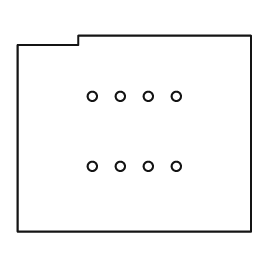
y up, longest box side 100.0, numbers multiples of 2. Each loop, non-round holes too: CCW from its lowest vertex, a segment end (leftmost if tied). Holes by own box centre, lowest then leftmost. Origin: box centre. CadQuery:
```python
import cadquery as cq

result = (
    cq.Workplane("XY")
    .moveTo(-50.0, -42.0)
    .lineTo(50.0, -42.0)
    .lineTo(50.0, 42.0)
    .lineTo(-24.0, 42.0)
    .lineTo(-24.0, 38.0)
    .lineTo(-50.0, 38.0)
    .close()
    .moveTo(-18.0, -14.0)
    .circle(2.0)
    .moveTo(-6.0, -14.0)
    .circle(2.0)
    .moveTo(6.0, -14.0)
    .circle(2.0)
    .moveTo(18.0, -14.0)
    .circle(2.0)
    .moveTo(-18.0, 16.0)
    .circle(2.0)
    .moveTo(-6.0, 16.0)
    .circle(2.0)
    .moveTo(6.0, 16.0)
    .circle(2.0)
    .moveTo(18.0, 16.0)
    .circle(2.0)
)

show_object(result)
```